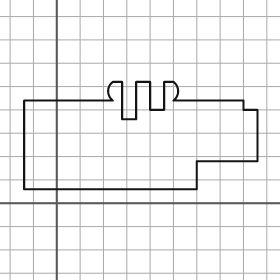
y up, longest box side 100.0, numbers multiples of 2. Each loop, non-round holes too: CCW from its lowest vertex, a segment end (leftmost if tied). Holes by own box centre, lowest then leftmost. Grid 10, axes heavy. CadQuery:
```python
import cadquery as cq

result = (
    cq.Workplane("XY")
    .moveTo(-14.0, 6.0)
    .lineTo(60.0, 6.0)
    .lineTo(60.0, 18.0)
    .lineTo(86.0, 18.0)
    .lineTo(86.0, 40.0)
    .lineTo(80.0, 40.0)
    .lineTo(80.0, 44.0)
    .lineTo(50.0, 44.0)
    .threePointArc((52.0, 48.0), (50.0, 52.0))
    .lineTo(46.0, 52.0)
    .lineTo(46.0, 40.0)
    .lineTo(40.0, 40.0)
    .lineTo(40.0, 52.0)
    .lineTo(34.0, 52.0)
    .lineTo(34.0, 36.0)
    .lineTo(28.0, 36.0)
    .lineTo(28.0, 52.0)
    .lineTo(24.0, 52.0)
    .threePointArc((22.0, 48.0), (24.0, 44.0))
    .lineTo(-14.0, 44.0)
    .close()
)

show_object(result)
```